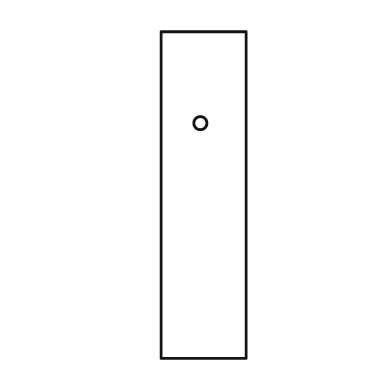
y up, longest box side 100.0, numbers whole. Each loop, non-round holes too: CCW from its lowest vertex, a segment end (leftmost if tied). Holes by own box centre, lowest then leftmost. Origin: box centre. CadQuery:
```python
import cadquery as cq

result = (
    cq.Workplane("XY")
    .moveTo(-13.0, -50.0)
    .lineTo(13.0, -50.0)
    .lineTo(13.0, 50.0)
    .lineTo(-13.0, 50.0)
    .close()
    .moveTo(-1.0, 22.0)
    .circle(2.0)
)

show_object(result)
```